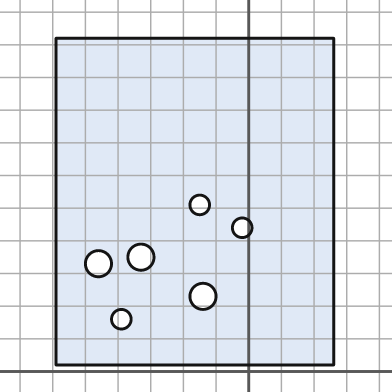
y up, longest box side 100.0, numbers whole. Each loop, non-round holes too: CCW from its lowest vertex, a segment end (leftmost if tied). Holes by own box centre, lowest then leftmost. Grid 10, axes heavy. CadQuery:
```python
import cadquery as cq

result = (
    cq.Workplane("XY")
    .moveTo(-59.0, 2.0)
    .lineTo(26.0, 2.0)
    .lineTo(26.0, 102.0)
    .lineTo(-59.0, 102.0)
    .close()
    .moveTo(-39.0, 16.0)
    .circle(3.0)
    .moveTo(-14.0, 23.0)
    .circle(4.0)
    .moveTo(-46.0, 33.0)
    .circle(4.0)
    .moveTo(-33.0, 35.0)
    .circle(4.0)
    .moveTo(-2.0, 44.0)
    .circle(3.0)
    .moveTo(-15.0, 51.0)
    .circle(3.0)
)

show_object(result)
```